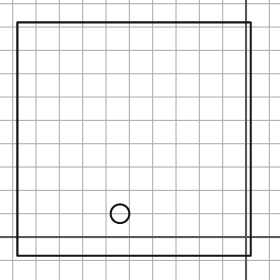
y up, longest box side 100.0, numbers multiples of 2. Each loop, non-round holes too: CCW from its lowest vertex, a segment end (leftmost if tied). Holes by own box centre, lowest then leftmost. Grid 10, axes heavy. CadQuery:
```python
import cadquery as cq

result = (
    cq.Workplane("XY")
    .moveTo(-98.0, -8.0)
    .lineTo(2.0, -8.0)
    .lineTo(2.0, 92.0)
    .lineTo(-98.0, 92.0)
    .close()
    .moveTo(-54.0, 10.0)
    .circle(4.0)
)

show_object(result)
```